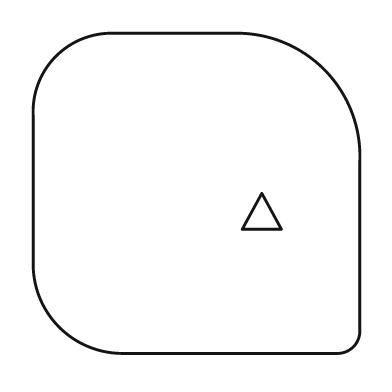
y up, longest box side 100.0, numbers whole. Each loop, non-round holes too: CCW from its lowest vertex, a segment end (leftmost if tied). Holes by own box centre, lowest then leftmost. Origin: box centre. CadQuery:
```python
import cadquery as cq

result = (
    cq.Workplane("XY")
    .moveTo(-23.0, -49.0)
    .lineTo(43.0, -49.0)
    .threePointArc((48.0, -47.0), (50.0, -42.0))
    .lineTo(50.0, 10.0)
    .threePointArc((39.0, 38.0), (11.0, 49.0))
    .lineTo(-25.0, 49.0)
    .threePointArc((-43.0, 42.0), (-50.0, 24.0))
    .lineTo(-50.0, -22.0)
    .threePointArc((-42.0, -41.0), (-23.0, -49.0))
    .close()
    .moveTo(14.0, -11.0)
    .lineTo(26.0, -11.0)
    .lineTo(20.0, 0.0)
    .close()
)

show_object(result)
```